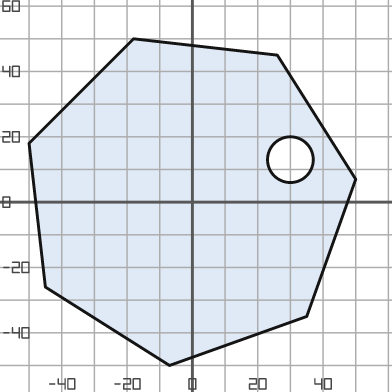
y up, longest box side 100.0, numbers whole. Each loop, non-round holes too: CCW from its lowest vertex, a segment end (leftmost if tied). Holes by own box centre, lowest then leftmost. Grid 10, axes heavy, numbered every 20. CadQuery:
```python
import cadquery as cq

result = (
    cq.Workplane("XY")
    .moveTo(-7.0, -50.0)
    .lineTo(35.0, -35.0)
    .lineTo(50.0, 7.0)
    .lineTo(26.0, 45.0)
    .lineTo(-18.0, 50.0)
    .lineTo(-50.0, 18.0)
    .lineTo(-45.0, -26.0)
    .close()
    .moveTo(30.0, 13.0)
    .circle(7.0)
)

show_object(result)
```